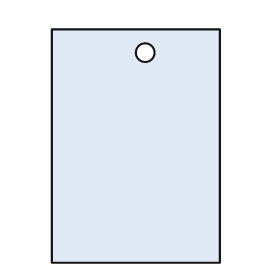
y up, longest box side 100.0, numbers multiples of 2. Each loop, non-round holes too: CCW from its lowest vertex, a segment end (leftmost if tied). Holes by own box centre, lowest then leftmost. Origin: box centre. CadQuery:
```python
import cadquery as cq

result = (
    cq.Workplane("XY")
    .moveTo(-36.0, -50.0)
    .lineTo(36.0, -50.0)
    .lineTo(36.0, 50.0)
    .lineTo(-36.0, 50.0)
    .close()
    .moveTo(4.0, 40.0)
    .circle(4.0)
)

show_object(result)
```